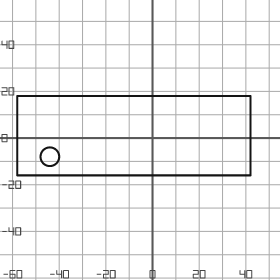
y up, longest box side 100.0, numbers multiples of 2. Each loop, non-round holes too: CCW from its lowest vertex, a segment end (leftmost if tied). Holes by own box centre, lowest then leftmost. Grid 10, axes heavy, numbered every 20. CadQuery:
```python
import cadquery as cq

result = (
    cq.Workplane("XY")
    .moveTo(-58.0, -16.0)
    .lineTo(42.0, -16.0)
    .lineTo(42.0, 18.0)
    .lineTo(-58.0, 18.0)
    .close()
    .moveTo(-44.0, -8.0)
    .circle(4.0)
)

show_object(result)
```